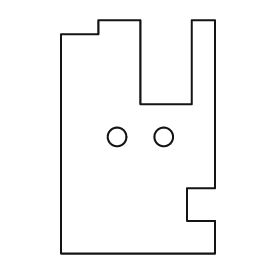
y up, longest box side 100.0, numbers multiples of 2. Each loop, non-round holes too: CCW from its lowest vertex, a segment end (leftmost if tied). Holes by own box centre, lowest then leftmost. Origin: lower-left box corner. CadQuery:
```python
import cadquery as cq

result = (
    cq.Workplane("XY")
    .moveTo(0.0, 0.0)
    .lineTo(66.0, 0.0)
    .lineTo(66.0, 14.0)
    .lineTo(54.0, 14.0)
    .lineTo(54.0, 28.0)
    .lineTo(66.0, 28.0)
    .lineTo(66.0, 100.0)
    .lineTo(56.0, 100.0)
    .lineTo(56.0, 64.0)
    .lineTo(34.0, 64.0)
    .lineTo(34.0, 100.0)
    .lineTo(16.0, 100.0)
    .lineTo(16.0, 94.0)
    .lineTo(0.0, 94.0)
    .close()
    .moveTo(24.0, 50.0)
    .circle(4.0)
    .moveTo(44.0, 50.0)
    .circle(4.0)
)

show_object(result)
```